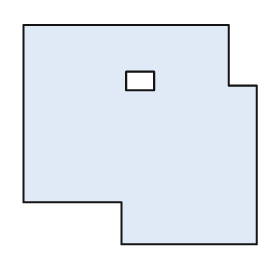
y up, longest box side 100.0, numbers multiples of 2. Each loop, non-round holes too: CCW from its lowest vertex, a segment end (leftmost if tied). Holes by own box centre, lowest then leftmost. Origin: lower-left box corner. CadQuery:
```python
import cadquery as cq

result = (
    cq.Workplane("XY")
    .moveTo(42.0, 0.0)
    .lineTo(100.0, 0.0)
    .lineTo(100.0, 68.0)
    .lineTo(88.0, 68.0)
    .lineTo(88.0, 94.0)
    .lineTo(0.0, 94.0)
    .lineTo(0.0, 18.0)
    .lineTo(42.0, 18.0)
    .close()
    .moveTo(44.0, 66.0)
    .lineTo(56.0, 66.0)
    .lineTo(56.0, 74.0)
    .lineTo(44.0, 74.0)
    .close()
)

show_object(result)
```